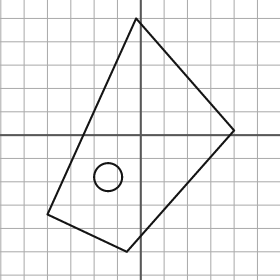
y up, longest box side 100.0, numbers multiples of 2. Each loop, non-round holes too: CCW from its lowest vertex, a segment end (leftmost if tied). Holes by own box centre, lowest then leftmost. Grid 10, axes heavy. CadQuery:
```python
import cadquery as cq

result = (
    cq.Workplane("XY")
    .moveTo(-6.0, -50.0)
    .lineTo(40.0, 2.0)
    .lineTo(-2.0, 50.0)
    .lineTo(-40.0, -34.0)
    .close()
    .moveTo(-14.0, -18.0)
    .circle(6.0)
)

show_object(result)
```